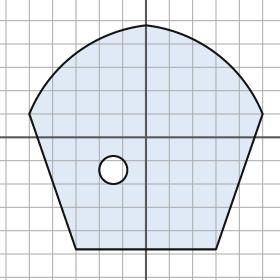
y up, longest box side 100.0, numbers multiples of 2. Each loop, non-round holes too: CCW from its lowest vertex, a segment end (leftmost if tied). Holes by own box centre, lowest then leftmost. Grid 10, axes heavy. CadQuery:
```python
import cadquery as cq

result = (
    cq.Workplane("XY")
    .moveTo(-30.0, -48.0)
    .lineTo(30.0, -48.0)
    .lineTo(50.0, 10.0)
    .threePointArc((30.0, 36.0), (0.0, 48.0))
    .threePointArc((-30.0, 36.0), (-50.0, 10.0))
    .close()
    .moveTo(-14.0, -14.0)
    .circle(6.0)
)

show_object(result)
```